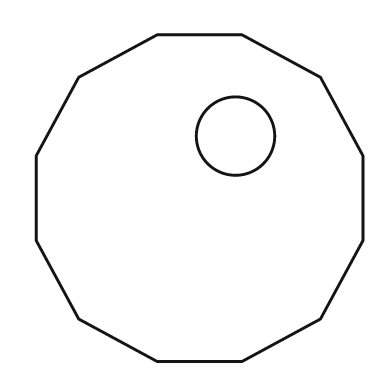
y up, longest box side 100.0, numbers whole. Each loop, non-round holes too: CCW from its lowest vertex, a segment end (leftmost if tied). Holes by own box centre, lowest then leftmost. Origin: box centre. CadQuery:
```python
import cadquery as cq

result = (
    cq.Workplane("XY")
    .moveTo(-13.0, -50.0)
    .lineTo(13.0, -50.0)
    .lineTo(37.0, -37.0)
    .lineTo(50.0, -13.0)
    .lineTo(50.0, 13.0)
    .lineTo(37.0, 37.0)
    .lineTo(13.0, 50.0)
    .lineTo(-13.0, 50.0)
    .lineTo(-37.0, 37.0)
    .lineTo(-50.0, 13.0)
    .lineTo(-50.0, -13.0)
    .lineTo(-37.0, -37.0)
    .close()
    .moveTo(11.0, 19.0)
    .circle(12.0)
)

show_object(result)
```